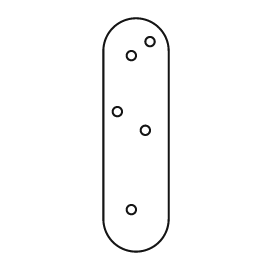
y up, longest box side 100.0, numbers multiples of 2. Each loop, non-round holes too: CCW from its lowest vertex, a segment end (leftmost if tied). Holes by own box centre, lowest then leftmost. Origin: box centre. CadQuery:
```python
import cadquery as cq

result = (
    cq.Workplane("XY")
    .moveTo(-14.0, -36.0)
    .threePointArc((0.0, -50.0), (14.0, -36.0))
    .lineTo(14.0, 36.0)
    .threePointArc((0.0, 50.0), (-14.0, 36.0))
    .close()
    .moveTo(-2.0, -32.0)
    .circle(2.0)
    .moveTo(4.0, 2.0)
    .circle(2.0)
    .moveTo(-8.0, 10.0)
    .circle(2.0)
    .moveTo(-2.0, 34.0)
    .circle(2.0)
    .moveTo(6.0, 40.0)
    .circle(2.0)
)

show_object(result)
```